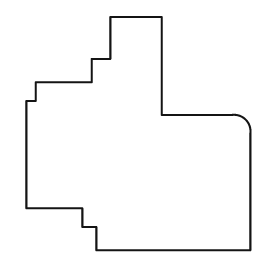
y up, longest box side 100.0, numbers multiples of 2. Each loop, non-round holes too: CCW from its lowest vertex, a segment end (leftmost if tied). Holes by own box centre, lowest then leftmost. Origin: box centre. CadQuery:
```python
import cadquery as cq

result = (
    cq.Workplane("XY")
    .moveTo(-18.0, -50.0)
    .lineTo(48.0, -50.0)
    .lineTo(48.0, 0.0)
    .threePointArc((46.0, 6.0), (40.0, 8.0))
    .lineTo(10.0, 8.0)
    .lineTo(10.0, 50.0)
    .lineTo(-12.0, 50.0)
    .lineTo(-12.0, 32.0)
    .lineTo(-20.0, 32.0)
    .lineTo(-20.0, 22.0)
    .lineTo(-44.0, 22.0)
    .lineTo(-44.0, 14.0)
    .lineTo(-48.0, 14.0)
    .lineTo(-48.0, -32.0)
    .lineTo(-24.0, -32.0)
    .lineTo(-24.0, -40.0)
    .lineTo(-18.0, -40.0)
    .close()
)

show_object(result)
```